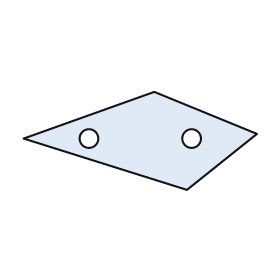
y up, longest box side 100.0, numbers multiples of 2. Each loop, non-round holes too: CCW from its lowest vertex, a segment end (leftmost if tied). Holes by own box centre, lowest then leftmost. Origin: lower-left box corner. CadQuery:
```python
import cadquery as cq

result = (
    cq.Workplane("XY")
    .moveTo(70.0, 0.0)
    .lineTo(100.0, 24.0)
    .lineTo(56.0, 42.0)
    .lineTo(0.0, 22.0)
    .close()
    .moveTo(28.0, 22.0)
    .circle(4.0)
    .moveTo(72.0, 22.0)
    .circle(4.0)
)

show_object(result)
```